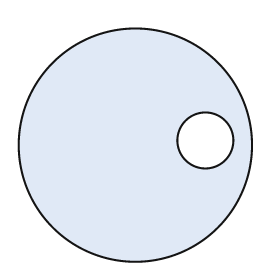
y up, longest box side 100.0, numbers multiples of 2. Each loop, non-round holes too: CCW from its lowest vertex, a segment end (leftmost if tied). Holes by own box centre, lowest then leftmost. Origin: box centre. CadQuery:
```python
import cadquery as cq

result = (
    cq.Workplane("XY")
    .moveTo(0.0, 0.0)
    .circle(50.0)
    .moveTo(30.0, 2.0)
    .circle(12.0)
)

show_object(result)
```